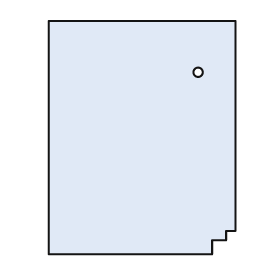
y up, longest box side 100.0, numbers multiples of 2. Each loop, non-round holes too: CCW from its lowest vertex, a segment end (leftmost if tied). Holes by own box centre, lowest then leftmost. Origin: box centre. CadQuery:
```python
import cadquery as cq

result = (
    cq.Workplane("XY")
    .moveTo(-40.0, -50.0)
    .lineTo(30.0, -50.0)
    .lineTo(30.0, -44.0)
    .lineTo(36.0, -44.0)
    .lineTo(36.0, -40.0)
    .lineTo(40.0, -40.0)
    .lineTo(40.0, 50.0)
    .lineTo(-40.0, 50.0)
    .close()
    .moveTo(24.0, 28.0)
    .circle(2.0)
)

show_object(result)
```